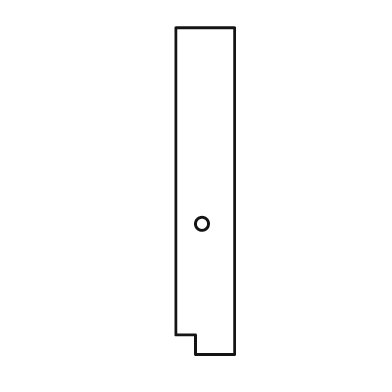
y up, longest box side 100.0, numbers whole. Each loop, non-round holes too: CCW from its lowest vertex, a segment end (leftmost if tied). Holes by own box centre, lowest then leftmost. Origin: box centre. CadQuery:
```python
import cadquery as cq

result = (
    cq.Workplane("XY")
    .moveTo(-3.0, -50.0)
    .lineTo(9.0, -50.0)
    .lineTo(9.0, 50.0)
    .lineTo(-9.0, 50.0)
    .lineTo(-9.0, -44.0)
    .lineTo(-3.0, -44.0)
    .close()
    .moveTo(-1.0, -10.0)
    .circle(2.0)
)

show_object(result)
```